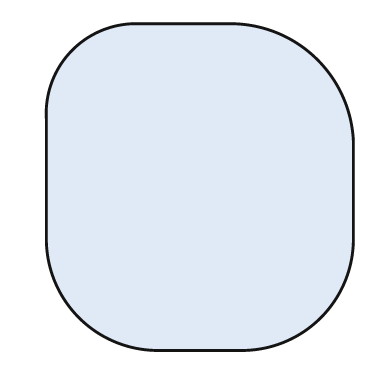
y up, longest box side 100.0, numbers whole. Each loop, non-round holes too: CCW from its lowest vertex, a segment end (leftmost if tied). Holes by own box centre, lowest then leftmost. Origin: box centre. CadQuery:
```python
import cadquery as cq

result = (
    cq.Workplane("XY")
    .moveTo(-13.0, -50.0)
    .lineTo(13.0, -50.0)
    .threePointArc((37.0, -40.0), (47.0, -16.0))
    .lineTo(47.0, 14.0)
    .threePointArc((36.0, 39.0), (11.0, 50.0))
    .lineTo(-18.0, 50.0)
    .threePointArc((-39.0, 42.0), (-47.0, 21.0))
    .lineTo(-47.0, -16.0)
    .threePointArc((-37.0, -40.0), (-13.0, -50.0))
    .close()
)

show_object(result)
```